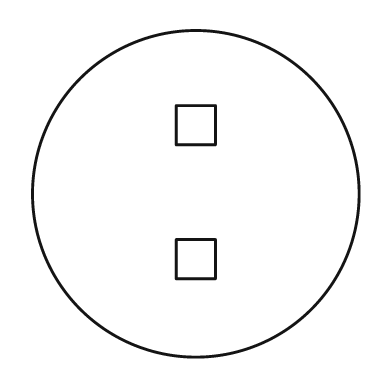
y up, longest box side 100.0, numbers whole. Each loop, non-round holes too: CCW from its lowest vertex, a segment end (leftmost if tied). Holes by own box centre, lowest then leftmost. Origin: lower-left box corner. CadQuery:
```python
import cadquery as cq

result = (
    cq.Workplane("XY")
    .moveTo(50.0, 50.0)
    .circle(50.0)
    .moveTo(44.0, 24.0)
    .lineTo(56.0, 24.0)
    .lineTo(56.0, 36.0)
    .lineTo(44.0, 36.0)
    .close()
    .moveTo(44.0, 65.0)
    .lineTo(56.0, 65.0)
    .lineTo(56.0, 77.0)
    .lineTo(44.0, 77.0)
    .close()
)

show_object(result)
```